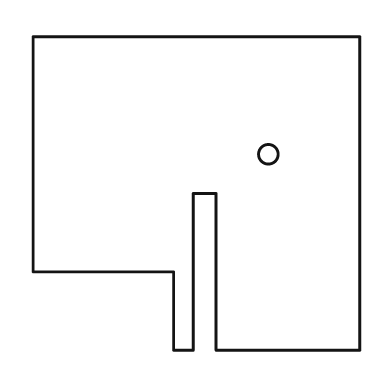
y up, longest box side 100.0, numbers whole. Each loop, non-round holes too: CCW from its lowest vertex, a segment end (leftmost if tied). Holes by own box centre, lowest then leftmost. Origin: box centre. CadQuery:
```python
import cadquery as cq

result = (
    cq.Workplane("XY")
    .moveTo(-7.0, -48.0)
    .lineTo(-1.0, -48.0)
    .lineTo(-1.0, 0.0)
    .lineTo(6.0, 0.0)
    .lineTo(6.0, -48.0)
    .lineTo(50.0, -48.0)
    .lineTo(50.0, 48.0)
    .lineTo(-50.0, 48.0)
    .lineTo(-50.0, -24.0)
    .lineTo(-7.0, -24.0)
    .close()
    .moveTo(22.0, 12.0)
    .circle(3.0)
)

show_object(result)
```